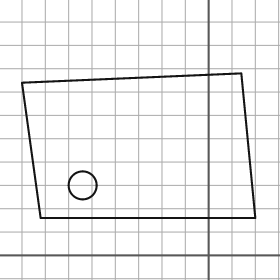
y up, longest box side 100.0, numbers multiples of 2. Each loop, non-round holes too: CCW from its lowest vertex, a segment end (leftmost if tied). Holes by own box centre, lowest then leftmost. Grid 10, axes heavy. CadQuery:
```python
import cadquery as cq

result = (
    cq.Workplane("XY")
    .moveTo(-72.0, 16.0)
    .lineTo(20.0, 16.0)
    .lineTo(14.0, 78.0)
    .lineTo(-80.0, 74.0)
    .close()
    .moveTo(-54.0, 30.0)
    .circle(6.0)
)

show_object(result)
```